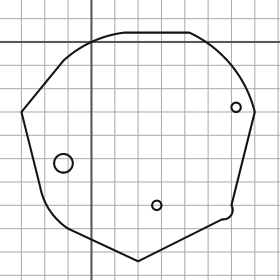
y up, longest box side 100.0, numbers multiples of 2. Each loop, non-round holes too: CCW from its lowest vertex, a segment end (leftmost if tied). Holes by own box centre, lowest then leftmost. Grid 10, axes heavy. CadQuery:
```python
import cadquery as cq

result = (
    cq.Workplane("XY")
    .moveTo(20.0, -94.0)
    .lineTo(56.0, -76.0)
    .threePointArc((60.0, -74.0), (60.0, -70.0))
    .lineTo(70.0, -30.0)
    .threePointArc((60.0, -10.0), (42.0, 4.0))
    .lineTo(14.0, 4.0)
    .threePointArc((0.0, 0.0), (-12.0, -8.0))
    .lineTo(-30.0, -30.0)
    .lineTo(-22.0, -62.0)
    .threePointArc((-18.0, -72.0), (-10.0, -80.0))
    .close()
    .moveTo(28.0, -70.0)
    .circle(2.0)
    .moveTo(-12.0, -52.0)
    .circle(4.0)
    .moveTo(62.0, -28.0)
    .circle(2.0)
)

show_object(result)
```